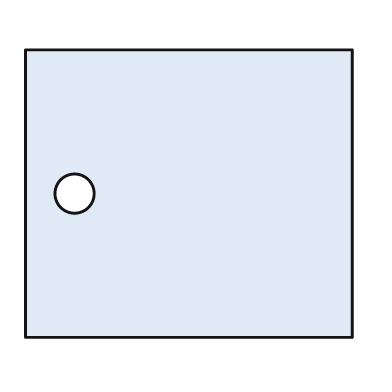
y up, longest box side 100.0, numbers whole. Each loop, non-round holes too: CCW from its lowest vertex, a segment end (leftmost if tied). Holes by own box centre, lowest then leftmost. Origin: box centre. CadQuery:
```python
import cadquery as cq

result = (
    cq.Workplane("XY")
    .moveTo(-50.0, -44.0)
    .lineTo(50.0, -44.0)
    .lineTo(50.0, 44.0)
    .lineTo(-50.0, 44.0)
    .close()
    .moveTo(-35.0, 0.0)
    .circle(6.0)
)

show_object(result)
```